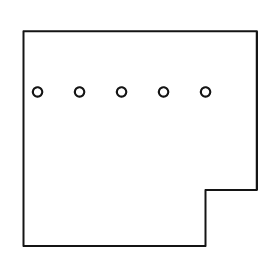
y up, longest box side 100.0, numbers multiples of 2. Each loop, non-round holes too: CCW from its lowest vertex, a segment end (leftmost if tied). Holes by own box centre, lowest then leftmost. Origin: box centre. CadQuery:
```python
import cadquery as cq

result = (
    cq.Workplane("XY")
    .moveTo(-50.0, -46.0)
    .lineTo(28.0, -46.0)
    .lineTo(28.0, -22.0)
    .lineTo(50.0, -22.0)
    .lineTo(50.0, 46.0)
    .lineTo(-50.0, 46.0)
    .close()
    .moveTo(-44.0, 20.0)
    .circle(2.0)
    .moveTo(-26.0, 20.0)
    .circle(2.0)
    .moveTo(-8.0, 20.0)
    .circle(2.0)
    .moveTo(10.0, 20.0)
    .circle(2.0)
    .moveTo(28.0, 20.0)
    .circle(2.0)
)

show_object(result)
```